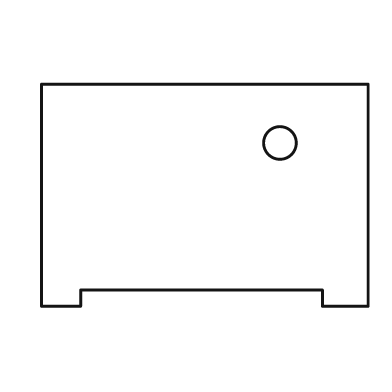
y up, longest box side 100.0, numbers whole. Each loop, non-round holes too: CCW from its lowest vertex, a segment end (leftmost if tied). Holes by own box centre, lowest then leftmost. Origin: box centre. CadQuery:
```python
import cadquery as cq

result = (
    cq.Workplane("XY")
    .moveTo(-50.0, -34.0)
    .lineTo(-38.0, -34.0)
    .lineTo(-38.0, -29.0)
    .lineTo(36.0, -29.0)
    .lineTo(36.0, -34.0)
    .lineTo(50.0, -34.0)
    .lineTo(50.0, 34.0)
    .lineTo(-50.0, 34.0)
    .close()
    .moveTo(23.0, 16.0)
    .circle(5.0)
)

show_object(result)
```